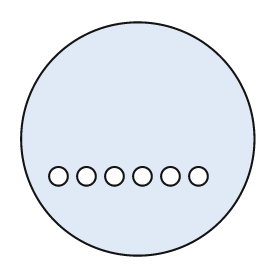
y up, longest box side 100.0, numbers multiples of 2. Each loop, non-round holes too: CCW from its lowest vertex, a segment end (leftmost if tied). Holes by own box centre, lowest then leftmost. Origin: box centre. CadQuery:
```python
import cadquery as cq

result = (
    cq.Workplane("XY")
    .moveTo(0.0, 0.0)
    .circle(50.0)
    .moveTo(-34.0, -16.0)
    .circle(4.0)
    .moveTo(-22.0, -16.0)
    .circle(4.0)
    .moveTo(-10.0, -16.0)
    .circle(4.0)
    .moveTo(2.0, -16.0)
    .circle(4.0)
    .moveTo(14.0, -16.0)
    .circle(4.0)
    .moveTo(26.0, -16.0)
    .circle(4.0)
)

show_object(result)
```